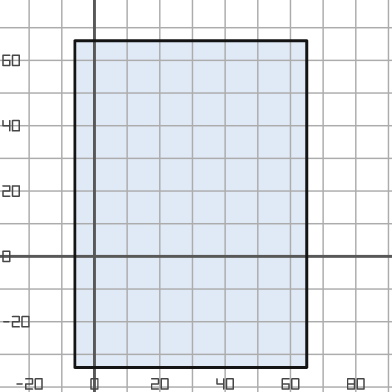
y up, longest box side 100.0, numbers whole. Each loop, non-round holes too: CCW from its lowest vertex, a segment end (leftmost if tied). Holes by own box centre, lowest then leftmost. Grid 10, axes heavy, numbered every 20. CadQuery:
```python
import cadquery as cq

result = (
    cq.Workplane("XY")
    .moveTo(-6.0, -34.0)
    .lineTo(65.0, -34.0)
    .lineTo(65.0, 66.0)
    .lineTo(-6.0, 66.0)
    .close()
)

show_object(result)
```